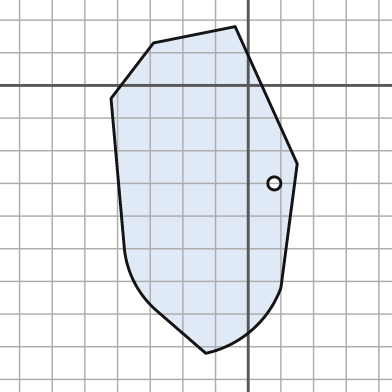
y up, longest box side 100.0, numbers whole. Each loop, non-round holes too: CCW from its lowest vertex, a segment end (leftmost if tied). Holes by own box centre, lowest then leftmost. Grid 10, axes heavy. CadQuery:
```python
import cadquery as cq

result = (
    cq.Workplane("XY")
    .moveTo(-13.0, -82.0)
    .threePointArc((1.0, -75.0), (10.0, -62.0))
    .lineTo(15.0, -24.0)
    .lineTo(-4.0, 18.0)
    .lineTo(-29.0, 13.0)
    .lineTo(-42.0, -4.0)
    .lineTo(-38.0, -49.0)
    .threePointArc((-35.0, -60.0), (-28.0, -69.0))
    .close()
    .moveTo(8.0, -30.0)
    .circle(2.0)
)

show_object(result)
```